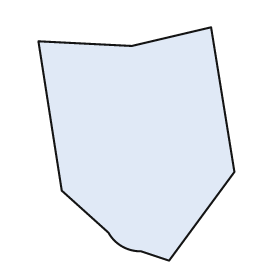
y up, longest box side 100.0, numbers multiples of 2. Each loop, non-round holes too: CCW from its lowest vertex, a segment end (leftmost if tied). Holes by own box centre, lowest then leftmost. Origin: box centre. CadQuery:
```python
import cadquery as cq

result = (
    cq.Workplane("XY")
    .moveTo(14.0, -50.0)
    .lineTo(42.0, -12.0)
    .lineTo(32.0, 50.0)
    .lineTo(-2.0, 42.0)
    .lineTo(-42.0, 44.0)
    .lineTo(-32.0, -20.0)
    .lineTo(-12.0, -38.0)
    .threePointArc((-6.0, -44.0), (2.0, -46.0))
    .close()
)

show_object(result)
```